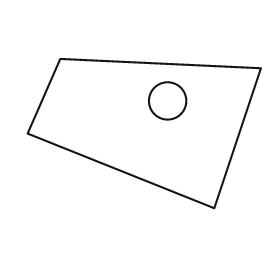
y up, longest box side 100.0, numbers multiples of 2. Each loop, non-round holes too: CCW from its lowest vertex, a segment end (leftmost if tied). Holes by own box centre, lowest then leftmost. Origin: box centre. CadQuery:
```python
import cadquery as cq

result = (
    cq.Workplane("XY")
    .moveTo(30.0, -32.0)
    .lineTo(50.0, 28.0)
    .lineTo(-36.0, 32.0)
    .lineTo(-50.0, 0.0)
    .close()
    .moveTo(10.0, 14.0)
    .circle(8.0)
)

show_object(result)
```